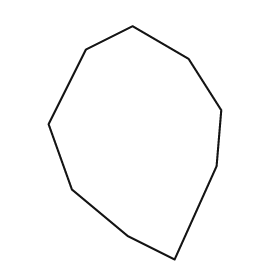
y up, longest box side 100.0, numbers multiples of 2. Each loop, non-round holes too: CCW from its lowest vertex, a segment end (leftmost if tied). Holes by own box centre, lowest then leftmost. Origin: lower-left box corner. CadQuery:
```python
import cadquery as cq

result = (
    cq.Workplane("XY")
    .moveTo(54.0, 0.0)
    .lineTo(72.0, 40.0)
    .lineTo(74.0, 64.0)
    .lineTo(60.0, 86.0)
    .lineTo(36.0, 100.0)
    .lineTo(16.0, 90.0)
    .lineTo(0.0, 58.0)
    .lineTo(10.0, 30.0)
    .lineTo(34.0, 10.0)
    .close()
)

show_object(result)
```